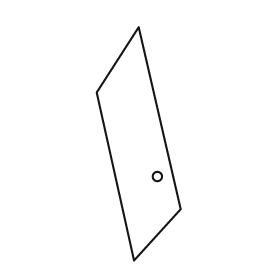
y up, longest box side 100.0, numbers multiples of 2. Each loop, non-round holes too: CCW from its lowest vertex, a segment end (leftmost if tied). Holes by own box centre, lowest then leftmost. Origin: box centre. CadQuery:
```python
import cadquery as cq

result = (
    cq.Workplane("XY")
    .moveTo(-2.0, -50.0)
    .lineTo(18.0, -28.0)
    .lineTo(0.0, 50.0)
    .lineTo(-18.0, 22.0)
    .close()
    .moveTo(8.0, -14.0)
    .circle(2.0)
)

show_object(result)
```